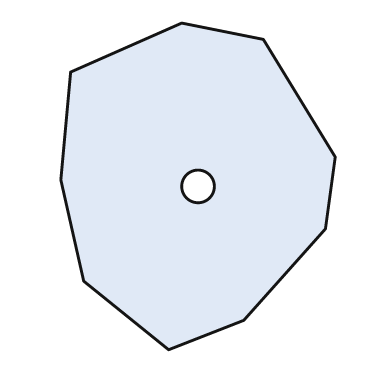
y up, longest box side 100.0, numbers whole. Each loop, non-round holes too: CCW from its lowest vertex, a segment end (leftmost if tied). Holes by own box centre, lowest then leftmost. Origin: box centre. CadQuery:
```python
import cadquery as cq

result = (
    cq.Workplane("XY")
    .moveTo(-9.0, -50.0)
    .lineTo(14.0, -41.0)
    .lineTo(39.0, -13.0)
    .lineTo(42.0, 9.0)
    .lineTo(20.0, 45.0)
    .lineTo(-5.0, 50.0)
    .lineTo(-39.0, 35.0)
    .lineTo(-42.0, 2.0)
    .lineTo(-35.0, -29.0)
    .close()
    .moveTo(0.0, 0.0)
    .circle(5.0)
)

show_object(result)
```